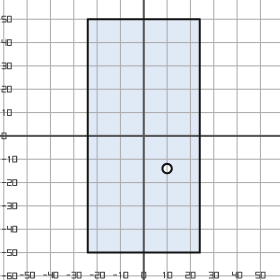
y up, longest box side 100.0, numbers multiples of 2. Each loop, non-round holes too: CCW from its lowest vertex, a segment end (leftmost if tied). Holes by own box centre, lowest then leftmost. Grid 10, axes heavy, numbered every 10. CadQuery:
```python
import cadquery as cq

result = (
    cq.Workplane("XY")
    .moveTo(-24.0, -50.0)
    .lineTo(24.0, -50.0)
    .lineTo(24.0, 50.0)
    .lineTo(-24.0, 50.0)
    .close()
    .moveTo(10.0, -14.0)
    .circle(2.0)
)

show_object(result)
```